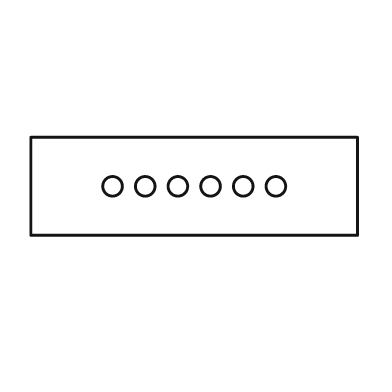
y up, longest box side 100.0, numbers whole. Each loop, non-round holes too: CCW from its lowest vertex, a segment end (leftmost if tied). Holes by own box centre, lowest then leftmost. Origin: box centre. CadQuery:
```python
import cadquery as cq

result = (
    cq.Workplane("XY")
    .moveTo(-50.0, -15.0)
    .lineTo(50.0, -15.0)
    .lineTo(50.0, 15.0)
    .lineTo(-50.0, 15.0)
    .close()
    .moveTo(-25.0, 0.0)
    .circle(3.0)
    .moveTo(-15.0, 0.0)
    .circle(3.0)
    .moveTo(-5.0, 0.0)
    .circle(3.0)
    .moveTo(5.0, 0.0)
    .circle(3.0)
    .moveTo(15.0, 0.0)
    .circle(3.0)
    .moveTo(25.0, 0.0)
    .circle(3.0)
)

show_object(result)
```